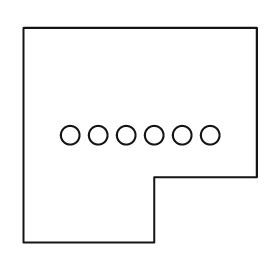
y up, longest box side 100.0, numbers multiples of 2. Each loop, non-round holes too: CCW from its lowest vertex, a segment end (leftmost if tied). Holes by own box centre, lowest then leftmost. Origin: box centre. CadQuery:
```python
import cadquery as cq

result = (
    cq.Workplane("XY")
    .moveTo(-50.0, -46.0)
    .lineTo(6.0, -46.0)
    .lineTo(6.0, -18.0)
    .lineTo(50.0, -18.0)
    .lineTo(50.0, 46.0)
    .lineTo(-50.0, 46.0)
    .close()
    .moveTo(-30.0, 0.0)
    .circle(4.0)
    .moveTo(-18.0, 0.0)
    .circle(4.0)
    .moveTo(-6.0, 0.0)
    .circle(4.0)
    .moveTo(6.0, 0.0)
    .circle(4.0)
    .moveTo(18.0, 0.0)
    .circle(4.0)
    .moveTo(30.0, 0.0)
    .circle(4.0)
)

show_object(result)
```